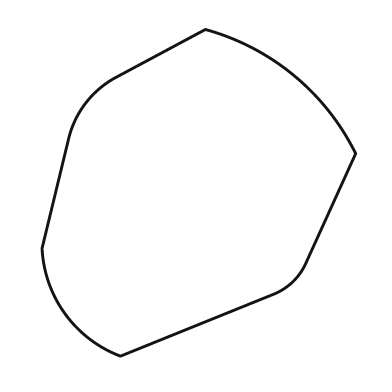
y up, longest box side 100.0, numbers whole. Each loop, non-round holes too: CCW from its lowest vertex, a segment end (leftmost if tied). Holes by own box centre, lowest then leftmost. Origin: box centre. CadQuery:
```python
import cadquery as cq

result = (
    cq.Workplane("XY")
    .moveTo(-24.0, -50.0)
    .lineTo(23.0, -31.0)
    .threePointArc((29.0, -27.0), (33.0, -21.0))
    .lineTo(48.0, 12.0)
    .threePointArc((29.0, 36.0), (2.0, 50.0))
    .lineTo(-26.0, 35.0)
    .threePointArc((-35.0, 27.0), (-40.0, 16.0))
    .lineTo(-48.0, -17.0)
    .threePointArc((-41.0, -37.0), (-24.0, -50.0))
    .close()
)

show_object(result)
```